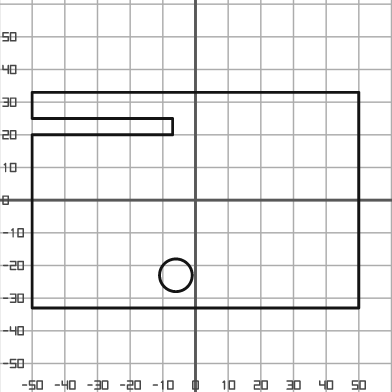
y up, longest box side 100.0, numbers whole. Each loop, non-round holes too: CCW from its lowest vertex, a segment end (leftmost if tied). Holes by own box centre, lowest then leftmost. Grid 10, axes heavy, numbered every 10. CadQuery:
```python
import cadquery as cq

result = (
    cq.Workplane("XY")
    .moveTo(-50.0, -33.0)
    .lineTo(50.0, -33.0)
    .lineTo(50.0, 33.0)
    .lineTo(-50.0, 33.0)
    .lineTo(-50.0, 25.0)
    .lineTo(-7.0, 25.0)
    .lineTo(-7.0, 20.0)
    .lineTo(-50.0, 20.0)
    .close()
    .moveTo(-6.0, -23.0)
    .circle(5.0)
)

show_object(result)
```